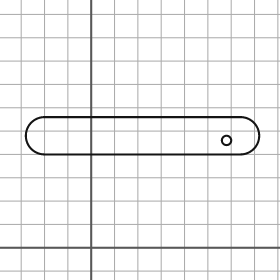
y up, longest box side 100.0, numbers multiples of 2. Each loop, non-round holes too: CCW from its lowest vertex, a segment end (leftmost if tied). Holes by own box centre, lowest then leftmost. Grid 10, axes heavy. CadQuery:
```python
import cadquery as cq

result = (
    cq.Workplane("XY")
    .moveTo(-20.0, 40.0)
    .lineTo(64.0, 40.0)
    .threePointArc((72.0, 48.0), (64.0, 56.0))
    .lineTo(-20.0, 56.0)
    .threePointArc((-28.0, 48.0), (-20.0, 40.0))
    .close()
    .moveTo(58.0, 46.0)
    .circle(2.0)
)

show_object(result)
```